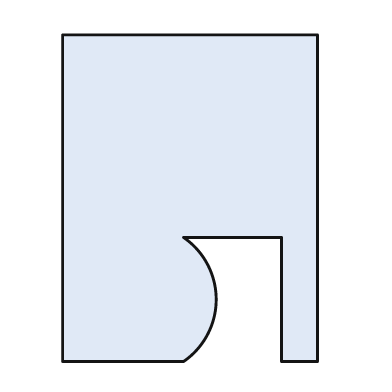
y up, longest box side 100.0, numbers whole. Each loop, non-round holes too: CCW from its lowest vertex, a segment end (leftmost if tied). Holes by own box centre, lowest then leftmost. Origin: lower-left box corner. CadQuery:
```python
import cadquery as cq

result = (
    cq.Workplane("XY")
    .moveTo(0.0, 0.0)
    .lineTo(37.0, 0.0)
    .threePointArc((47.0, 19.0), (37.0, 38.0))
    .lineTo(67.0, 38.0)
    .lineTo(67.0, 0.0)
    .lineTo(78.0, 0.0)
    .lineTo(78.0, 100.0)
    .lineTo(0.0, 100.0)
    .close()
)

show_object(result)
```